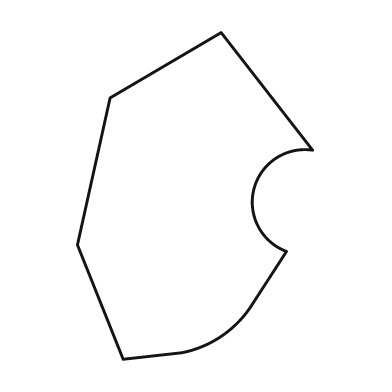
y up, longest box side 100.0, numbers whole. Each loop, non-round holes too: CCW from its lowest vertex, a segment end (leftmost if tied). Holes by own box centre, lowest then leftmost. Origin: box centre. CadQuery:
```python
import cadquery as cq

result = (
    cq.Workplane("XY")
    .moveTo(-22.0, -50.0)
    .lineTo(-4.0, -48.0)
    .threePointArc((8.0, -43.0), (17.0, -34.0))
    .lineTo(28.0, -17.0)
    .threePointArc((18.0, 2.0), (36.0, 14.0))
    .lineTo(8.0, 50.0)
    .lineTo(-26.0, 30.0)
    .lineTo(-36.0, -15.0)
    .close()
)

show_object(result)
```